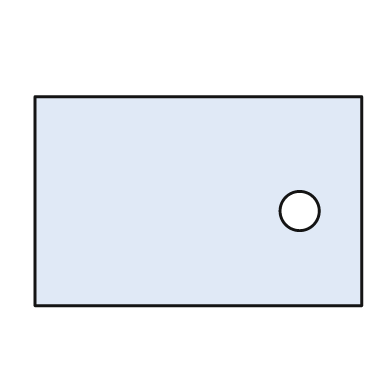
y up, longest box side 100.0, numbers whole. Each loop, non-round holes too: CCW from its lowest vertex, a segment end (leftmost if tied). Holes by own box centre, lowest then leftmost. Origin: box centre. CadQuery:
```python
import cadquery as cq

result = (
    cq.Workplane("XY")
    .moveTo(-50.0, -32.0)
    .lineTo(50.0, -32.0)
    .lineTo(50.0, 32.0)
    .lineTo(-50.0, 32.0)
    .close()
    .moveTo(31.0, -3.0)
    .circle(6.0)
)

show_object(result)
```